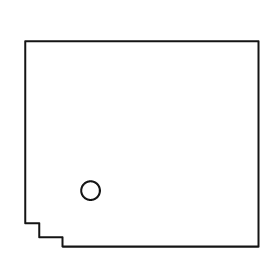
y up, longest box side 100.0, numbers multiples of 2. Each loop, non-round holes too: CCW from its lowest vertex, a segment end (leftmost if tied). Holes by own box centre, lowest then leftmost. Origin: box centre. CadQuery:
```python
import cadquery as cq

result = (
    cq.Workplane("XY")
    .moveTo(-34.0, -44.0)
    .lineTo(50.0, -44.0)
    .lineTo(50.0, 44.0)
    .lineTo(-50.0, 44.0)
    .lineTo(-50.0, -34.0)
    .lineTo(-44.0, -34.0)
    .lineTo(-44.0, -40.0)
    .lineTo(-34.0, -40.0)
    .close()
    .moveTo(-22.0, -20.0)
    .circle(4.0)
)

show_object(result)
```